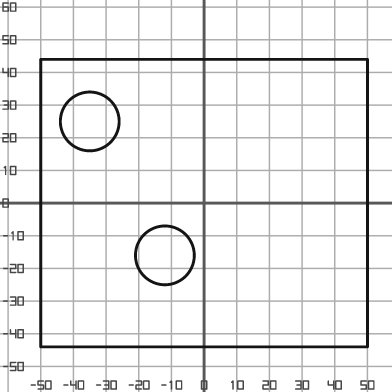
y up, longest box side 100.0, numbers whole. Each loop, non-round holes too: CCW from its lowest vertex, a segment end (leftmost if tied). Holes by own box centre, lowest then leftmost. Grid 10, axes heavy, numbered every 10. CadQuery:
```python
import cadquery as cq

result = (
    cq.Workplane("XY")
    .moveTo(-50.0, -44.0)
    .lineTo(50.0, -44.0)
    .lineTo(50.0, 44.0)
    .lineTo(-50.0, 44.0)
    .close()
    .moveTo(-12.0, -16.0)
    .circle(9.0)
    .moveTo(-35.0, 25.0)
    .circle(9.0)
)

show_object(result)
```